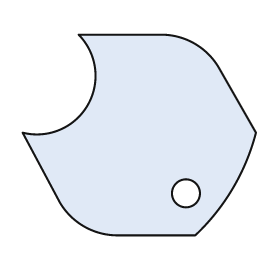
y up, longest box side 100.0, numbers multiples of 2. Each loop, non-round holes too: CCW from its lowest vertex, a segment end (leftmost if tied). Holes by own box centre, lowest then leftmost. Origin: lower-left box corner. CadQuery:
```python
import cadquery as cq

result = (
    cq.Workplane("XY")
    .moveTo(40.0, 0.0)
    .lineTo(74.0, 0.0)
    .threePointArc((90.0, 20.0), (100.0, 44.0))
    .lineTo(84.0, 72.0)
    .threePointArc((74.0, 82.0), (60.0, 86.0))
    .lineTo(24.0, 86.0)
    .threePointArc((28.0, 56.0), (0.0, 44.0))
    .lineTo(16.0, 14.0)
    .threePointArc((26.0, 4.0), (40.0, 0.0))
    .close()
    .moveTo(70.0, 18.0)
    .circle(6.0)
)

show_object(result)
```